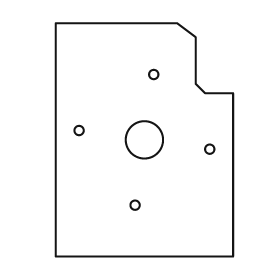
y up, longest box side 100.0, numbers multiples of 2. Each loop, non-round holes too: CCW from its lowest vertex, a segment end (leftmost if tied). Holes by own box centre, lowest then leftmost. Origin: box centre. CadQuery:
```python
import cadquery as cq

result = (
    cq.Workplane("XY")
    .moveTo(-38.0, -50.0)
    .lineTo(38.0, -50.0)
    .lineTo(38.0, 20.0)
    .lineTo(26.0, 20.0)
    .lineTo(22.0, 24.0)
    .lineTo(22.0, 44.0)
    .lineTo(14.0, 50.0)
    .lineTo(-38.0, 50.0)
    .close()
    .moveTo(-4.0, -28.0)
    .circle(2.0)
    .moveTo(28.0, -4.0)
    .circle(2.0)
    .moveTo(0.0, 0.0)
    .circle(8.0)
    .moveTo(-28.0, 4.0)
    .circle(2.0)
    .moveTo(4.0, 28.0)
    .circle(2.0)
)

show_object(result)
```